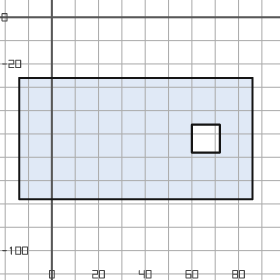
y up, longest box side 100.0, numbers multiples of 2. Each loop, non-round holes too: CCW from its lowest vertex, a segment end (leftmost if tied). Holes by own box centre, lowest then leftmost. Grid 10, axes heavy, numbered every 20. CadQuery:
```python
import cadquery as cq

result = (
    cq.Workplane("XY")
    .moveTo(-14.0, -78.0)
    .lineTo(86.0, -78.0)
    .lineTo(86.0, -26.0)
    .lineTo(-14.0, -26.0)
    .close()
    .moveTo(60.0, -58.0)
    .lineTo(72.0, -58.0)
    .lineTo(72.0, -46.0)
    .lineTo(60.0, -46.0)
    .close()
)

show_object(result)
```